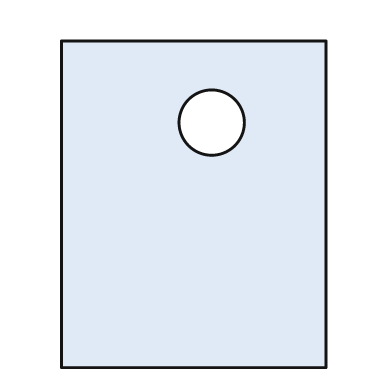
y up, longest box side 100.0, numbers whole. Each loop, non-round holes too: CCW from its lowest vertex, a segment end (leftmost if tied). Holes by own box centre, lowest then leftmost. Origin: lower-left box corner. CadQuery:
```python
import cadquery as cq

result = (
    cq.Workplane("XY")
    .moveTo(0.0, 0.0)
    .lineTo(81.0, 0.0)
    .lineTo(81.0, 100.0)
    .lineTo(0.0, 100.0)
    .close()
    .moveTo(46.0, 75.0)
    .circle(10.0)
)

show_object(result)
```